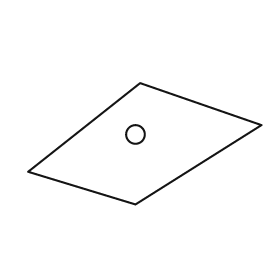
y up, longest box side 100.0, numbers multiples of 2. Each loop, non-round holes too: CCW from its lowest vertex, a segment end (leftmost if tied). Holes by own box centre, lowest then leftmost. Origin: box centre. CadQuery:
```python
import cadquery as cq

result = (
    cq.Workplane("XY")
    .moveTo(-4.0, -26.0)
    .lineTo(50.0, 8.0)
    .lineTo(-2.0, 26.0)
    .lineTo(-50.0, -12.0)
    .close()
    .moveTo(-4.0, 4.0)
    .circle(4.0)
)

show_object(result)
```